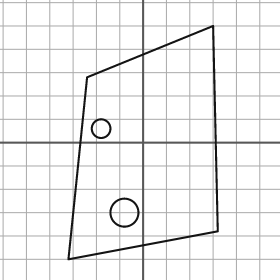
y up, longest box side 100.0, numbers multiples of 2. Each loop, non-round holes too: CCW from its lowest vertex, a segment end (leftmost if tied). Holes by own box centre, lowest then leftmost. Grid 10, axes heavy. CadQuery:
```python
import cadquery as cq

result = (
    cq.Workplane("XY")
    .moveTo(-32.0, -50.0)
    .lineTo(32.0, -38.0)
    .lineTo(30.0, 50.0)
    .lineTo(-24.0, 28.0)
    .close()
    .moveTo(-8.0, -30.0)
    .circle(6.0)
    .moveTo(-18.0, 6.0)
    .circle(4.0)
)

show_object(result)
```